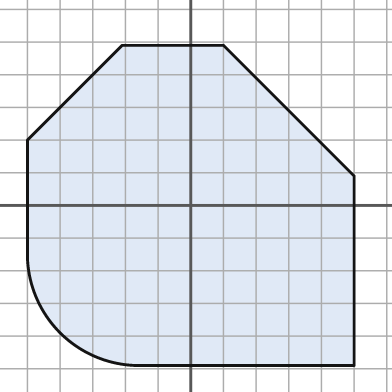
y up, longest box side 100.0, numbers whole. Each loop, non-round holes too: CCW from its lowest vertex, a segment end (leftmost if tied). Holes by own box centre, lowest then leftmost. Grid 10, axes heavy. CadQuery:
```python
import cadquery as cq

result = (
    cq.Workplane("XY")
    .moveTo(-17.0, -49.0)
    .lineTo(50.0, -49.0)
    .lineTo(50.0, 9.0)
    .lineTo(10.0, 49.0)
    .lineTo(-21.0, 49.0)
    .lineTo(-50.0, 20.0)
    .lineTo(-50.0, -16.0)
    .threePointArc((-40.0, -39.0), (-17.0, -49.0))
    .close()
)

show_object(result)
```